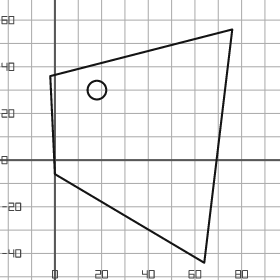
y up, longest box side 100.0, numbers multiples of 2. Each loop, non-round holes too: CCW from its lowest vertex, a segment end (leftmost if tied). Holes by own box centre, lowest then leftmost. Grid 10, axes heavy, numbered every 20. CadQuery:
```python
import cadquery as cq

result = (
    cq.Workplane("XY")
    .moveTo(64.0, -44.0)
    .lineTo(76.0, 56.0)
    .lineTo(-2.0, 36.0)
    .lineTo(0.0, -6.0)
    .close()
    .moveTo(18.0, 30.0)
    .circle(4.0)
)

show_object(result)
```